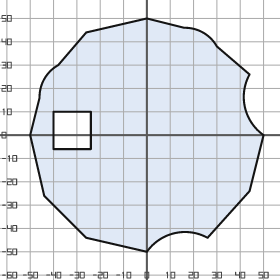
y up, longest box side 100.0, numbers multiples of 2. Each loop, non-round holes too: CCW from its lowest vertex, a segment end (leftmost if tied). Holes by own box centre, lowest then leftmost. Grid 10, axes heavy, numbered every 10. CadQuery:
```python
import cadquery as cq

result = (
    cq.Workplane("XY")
    .moveTo(0.0, -50.0)
    .threePointArc((12.0, -42.0), (26.0, -44.0))
    .lineTo(44.0, -24.0)
    .lineTo(50.0, 0.0)
    .threePointArc((42.0, 12.0), (44.0, 26.0))
    .lineTo(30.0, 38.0)
    .threePointArc((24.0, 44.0), (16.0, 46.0))
    .lineTo(0.0, 50.0)
    .lineTo(-26.0, 44.0)
    .lineTo(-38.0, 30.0)
    .threePointArc((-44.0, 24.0), (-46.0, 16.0))
    .lineTo(-50.0, 0.0)
    .lineTo(-44.0, -26.0)
    .lineTo(-26.0, -44.0)
    .close()
    .moveTo(-40.0, -6.0)
    .lineTo(-24.0, -6.0)
    .lineTo(-24.0, 10.0)
    .lineTo(-40.0, 10.0)
    .close()
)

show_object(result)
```